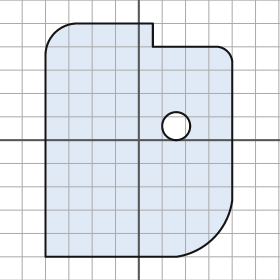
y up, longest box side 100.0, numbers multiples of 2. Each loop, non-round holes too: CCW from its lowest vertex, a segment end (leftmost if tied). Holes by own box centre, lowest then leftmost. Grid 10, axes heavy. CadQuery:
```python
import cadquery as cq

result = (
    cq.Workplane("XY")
    .moveTo(-40.0, -50.0)
    .lineTo(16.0, -50.0)
    .threePointArc((32.0, -42.0), (40.0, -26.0))
    .lineTo(40.0, 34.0)
    .threePointArc((38.0, 38.0), (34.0, 40.0))
    .lineTo(6.0, 40.0)
    .lineTo(6.0, 50.0)
    .lineTo(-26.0, 50.0)
    .threePointArc((-36.0, 46.0), (-40.0, 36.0))
    .close()
    .moveTo(16.0, 6.0)
    .circle(6.0)
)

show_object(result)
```